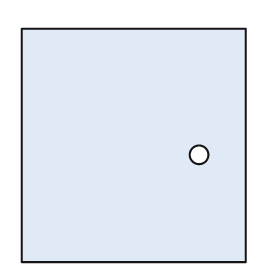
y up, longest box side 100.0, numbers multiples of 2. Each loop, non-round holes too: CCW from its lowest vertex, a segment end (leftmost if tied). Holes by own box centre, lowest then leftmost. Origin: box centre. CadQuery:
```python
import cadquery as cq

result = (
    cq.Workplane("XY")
    .moveTo(-48.0, -50.0)
    .lineTo(48.0, -50.0)
    .lineTo(48.0, 50.0)
    .lineTo(-48.0, 50.0)
    .close()
    .moveTo(28.0, -4.0)
    .circle(4.0)
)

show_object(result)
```